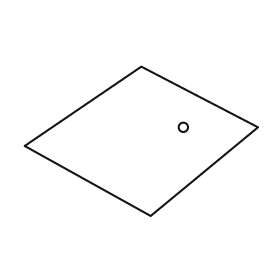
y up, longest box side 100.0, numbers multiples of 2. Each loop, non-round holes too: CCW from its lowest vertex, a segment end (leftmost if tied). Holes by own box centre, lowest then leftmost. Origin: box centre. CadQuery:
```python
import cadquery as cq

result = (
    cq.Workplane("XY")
    .moveTo(4.0, -32.0)
    .lineTo(50.0, 6.0)
    .lineTo(0.0, 32.0)
    .lineTo(-50.0, -2.0)
    .close()
    .moveTo(18.0, 6.0)
    .circle(2.0)
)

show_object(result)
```